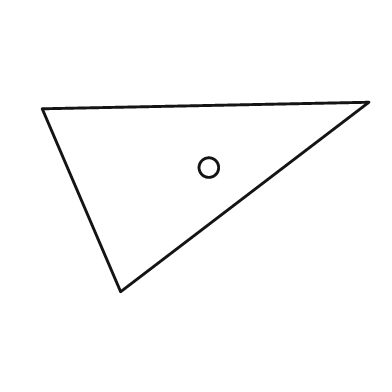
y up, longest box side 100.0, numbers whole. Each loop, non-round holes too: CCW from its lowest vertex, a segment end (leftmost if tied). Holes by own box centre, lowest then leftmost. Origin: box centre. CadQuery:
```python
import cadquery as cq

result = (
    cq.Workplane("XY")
    .moveTo(-26.0, -29.0)
    .lineTo(50.0, 29.0)
    .lineTo(-50.0, 27.0)
    .close()
    .moveTo(1.0, 9.0)
    .circle(3.0)
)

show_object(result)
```